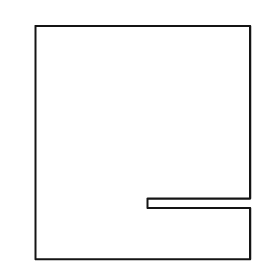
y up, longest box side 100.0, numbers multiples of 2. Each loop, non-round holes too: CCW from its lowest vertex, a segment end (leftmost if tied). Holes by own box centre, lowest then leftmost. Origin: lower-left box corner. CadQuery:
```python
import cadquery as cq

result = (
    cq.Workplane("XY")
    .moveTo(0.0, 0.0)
    .lineTo(92.0, 0.0)
    .lineTo(92.0, 22.0)
    .lineTo(48.0, 22.0)
    .lineTo(48.0, 26.0)
    .lineTo(92.0, 26.0)
    .lineTo(92.0, 100.0)
    .lineTo(0.0, 100.0)
    .close()
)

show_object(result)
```